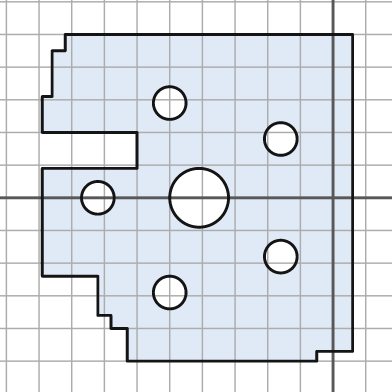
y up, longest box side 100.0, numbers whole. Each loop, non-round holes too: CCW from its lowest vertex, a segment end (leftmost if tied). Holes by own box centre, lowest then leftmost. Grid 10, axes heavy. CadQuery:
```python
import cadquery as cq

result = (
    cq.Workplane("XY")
    .moveTo(-63.0, -50.0)
    .lineTo(-5.0, -50.0)
    .lineTo(-5.0, -47.0)
    .lineTo(6.0, -47.0)
    .lineTo(6.0, 50.0)
    .lineTo(-82.0, 50.0)
    .lineTo(-82.0, 45.0)
    .lineTo(-86.0, 45.0)
    .lineTo(-86.0, 31.0)
    .lineTo(-89.0, 31.0)
    .lineTo(-89.0, 20.0)
    .lineTo(-60.0, 20.0)
    .lineTo(-60.0, 9.0)
    .lineTo(-89.0, 9.0)
    .lineTo(-89.0, -24.0)
    .lineTo(-72.0, -24.0)
    .lineTo(-72.0, -36.0)
    .lineTo(-68.0, -36.0)
    .lineTo(-68.0, -40.0)
    .lineTo(-63.0, -40.0)
    .close()
    .moveTo(-50.0, -29.0)
    .circle(5.0)
    .moveTo(-16.0, -18.0)
    .circle(5.0)
    .moveTo(-72.0, 0.0)
    .circle(5.0)
    .moveTo(-41.0, 0.0)
    .circle(9.0)
    .moveTo(-16.0, 18.0)
    .circle(5.0)
    .moveTo(-50.0, 29.0)
    .circle(5.0)
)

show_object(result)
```